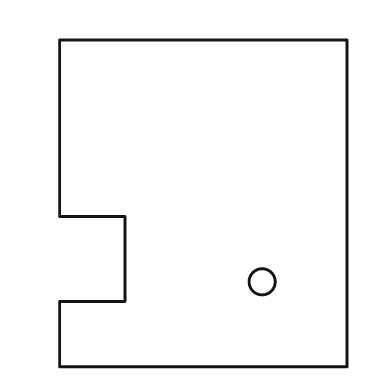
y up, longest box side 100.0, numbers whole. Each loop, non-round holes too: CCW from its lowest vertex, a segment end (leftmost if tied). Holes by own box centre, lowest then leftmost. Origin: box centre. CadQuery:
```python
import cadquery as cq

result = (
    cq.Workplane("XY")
    .moveTo(-44.0, -50.0)
    .lineTo(44.0, -50.0)
    .lineTo(44.0, 50.0)
    .lineTo(-44.0, 50.0)
    .lineTo(-44.0, -4.0)
    .lineTo(-24.0, -4.0)
    .lineTo(-24.0, -30.0)
    .lineTo(-44.0, -30.0)
    .close()
    .moveTo(18.0, -24.0)
    .circle(4.0)
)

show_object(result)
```